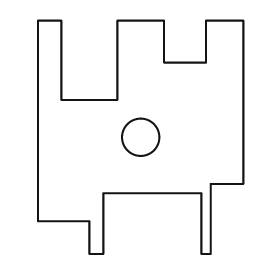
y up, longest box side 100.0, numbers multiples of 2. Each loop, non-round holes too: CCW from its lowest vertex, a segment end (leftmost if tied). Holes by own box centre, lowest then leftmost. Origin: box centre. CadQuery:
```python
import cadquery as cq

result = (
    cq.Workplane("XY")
    .moveTo(-22.0, -50.0)
    .lineTo(-16.0, -50.0)
    .lineTo(-16.0, -24.0)
    .lineTo(26.0, -24.0)
    .lineTo(26.0, -50.0)
    .lineTo(30.0, -50.0)
    .lineTo(30.0, -20.0)
    .lineTo(44.0, -20.0)
    .lineTo(44.0, 50.0)
    .lineTo(28.0, 50.0)
    .lineTo(28.0, 32.0)
    .lineTo(10.0, 32.0)
    .lineTo(10.0, 50.0)
    .lineTo(-10.0, 50.0)
    .lineTo(-10.0, 16.0)
    .lineTo(-34.0, 16.0)
    .lineTo(-34.0, 50.0)
    .lineTo(-44.0, 50.0)
    .lineTo(-44.0, -36.0)
    .lineTo(-22.0, -36.0)
    .close()
    .moveTo(0.0, 0.0)
    .circle(8.0)
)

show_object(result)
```